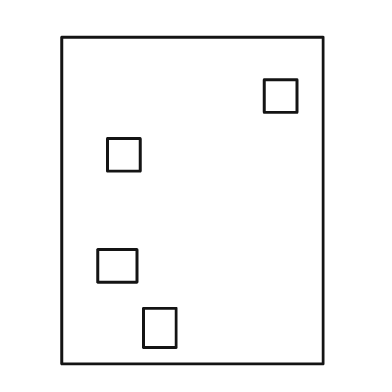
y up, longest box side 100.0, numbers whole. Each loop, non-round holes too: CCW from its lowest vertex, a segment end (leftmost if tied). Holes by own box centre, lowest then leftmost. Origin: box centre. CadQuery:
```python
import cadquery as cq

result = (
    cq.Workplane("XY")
    .moveTo(-40.0, -50.0)
    .lineTo(40.0, -50.0)
    .lineTo(40.0, 50.0)
    .lineTo(-40.0, 50.0)
    .close()
    .moveTo(-15.0, -45.0)
    .lineTo(-5.0, -45.0)
    .lineTo(-5.0, -33.0)
    .lineTo(-15.0, -33.0)
    .close()
    .moveTo(-29.0, -25.0)
    .lineTo(-17.0, -25.0)
    .lineTo(-17.0, -15.0)
    .lineTo(-29.0, -15.0)
    .close()
    .moveTo(-26.0, 9.0)
    .lineTo(-16.0, 9.0)
    .lineTo(-16.0, 19.0)
    .lineTo(-26.0, 19.0)
    .close()
    .moveTo(22.0, 27.0)
    .lineTo(32.0, 27.0)
    .lineTo(32.0, 37.0)
    .lineTo(22.0, 37.0)
    .close()
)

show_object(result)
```